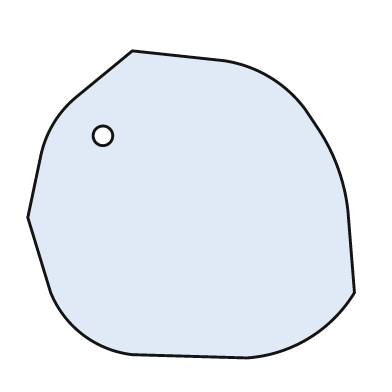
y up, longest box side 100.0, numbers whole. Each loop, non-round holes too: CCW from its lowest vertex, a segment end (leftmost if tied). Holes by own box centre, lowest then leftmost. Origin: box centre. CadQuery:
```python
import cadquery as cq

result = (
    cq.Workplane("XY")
    .moveTo(17.0, -47.0)
    .threePointArc((36.0, -41.0), (50.0, -27.0))
    .lineTo(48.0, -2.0)
    .threePointArc((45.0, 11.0), (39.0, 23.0))
    .lineTo(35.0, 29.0)
    .threePointArc((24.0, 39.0), (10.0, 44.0))
    .lineTo(-18.0, 47.0)
    .lineTo(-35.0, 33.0)
    .threePointArc((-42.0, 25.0), (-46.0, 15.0))
    .lineTo(-50.0, -4.0)
    .lineTo(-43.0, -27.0)
    .threePointArc((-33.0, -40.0), (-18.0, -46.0))
    .close()
    .moveTo(-27.0, 21.0)
    .circle(3.0)
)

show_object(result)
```